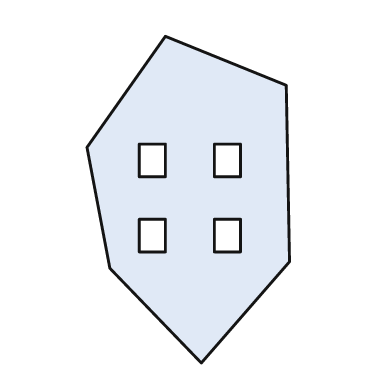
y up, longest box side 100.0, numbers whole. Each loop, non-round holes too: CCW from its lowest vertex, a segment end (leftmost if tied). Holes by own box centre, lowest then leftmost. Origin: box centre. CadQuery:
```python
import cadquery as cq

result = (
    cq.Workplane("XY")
    .moveTo(4.0, -50.0)
    .lineTo(31.0, -19.0)
    .lineTo(30.0, 35.0)
    .lineTo(-7.0, 50.0)
    .lineTo(-31.0, 16.0)
    .lineTo(-24.0, -21.0)
    .close()
    .moveTo(-15.0, -16.0)
    .lineTo(-7.0, -16.0)
    .lineTo(-7.0, -6.0)
    .lineTo(-15.0, -6.0)
    .close()
    .moveTo(8.0, -16.0)
    .lineTo(16.0, -16.0)
    .lineTo(16.0, -6.0)
    .lineTo(8.0, -6.0)
    .close()
    .moveTo(-15.0, 7.0)
    .lineTo(-7.0, 7.0)
    .lineTo(-7.0, 17.0)
    .lineTo(-15.0, 17.0)
    .close()
    .moveTo(8.0, 7.0)
    .lineTo(16.0, 7.0)
    .lineTo(16.0, 17.0)
    .lineTo(8.0, 17.0)
    .close()
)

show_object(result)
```